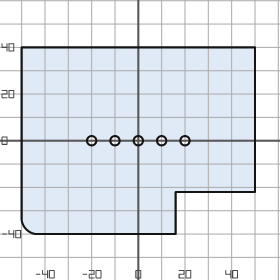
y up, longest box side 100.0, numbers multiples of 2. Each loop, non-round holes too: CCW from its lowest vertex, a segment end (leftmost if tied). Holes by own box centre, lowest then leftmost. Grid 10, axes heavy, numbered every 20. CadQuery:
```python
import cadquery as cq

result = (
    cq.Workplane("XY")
    .moveTo(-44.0, -40.0)
    .lineTo(16.0, -40.0)
    .lineTo(16.0, -22.0)
    .lineTo(50.0, -22.0)
    .lineTo(50.0, 40.0)
    .lineTo(-50.0, 40.0)
    .lineTo(-50.0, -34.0)
    .threePointArc((-48.0, -38.0), (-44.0, -40.0))
    .close()
    .moveTo(-20.0, 0.0)
    .circle(2.0)
    .moveTo(-10.0, 0.0)
    .circle(2.0)
    .moveTo(0.0, 0.0)
    .circle(2.0)
    .moveTo(10.0, 0.0)
    .circle(2.0)
    .moveTo(20.0, 0.0)
    .circle(2.0)
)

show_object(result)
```